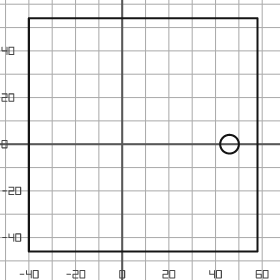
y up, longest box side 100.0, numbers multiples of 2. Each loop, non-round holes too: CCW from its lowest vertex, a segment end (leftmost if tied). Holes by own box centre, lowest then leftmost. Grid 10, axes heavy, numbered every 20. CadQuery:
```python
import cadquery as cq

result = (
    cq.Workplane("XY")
    .moveTo(-40.0, -46.0)
    .lineTo(58.0, -46.0)
    .lineTo(58.0, 54.0)
    .lineTo(-40.0, 54.0)
    .close()
    .moveTo(46.0, 0.0)
    .circle(4.0)
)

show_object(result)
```